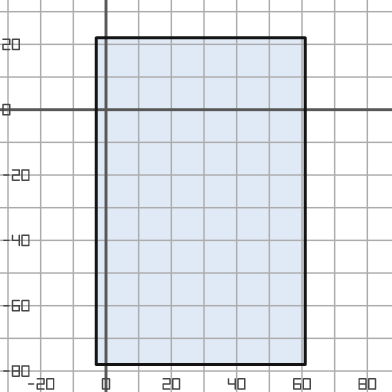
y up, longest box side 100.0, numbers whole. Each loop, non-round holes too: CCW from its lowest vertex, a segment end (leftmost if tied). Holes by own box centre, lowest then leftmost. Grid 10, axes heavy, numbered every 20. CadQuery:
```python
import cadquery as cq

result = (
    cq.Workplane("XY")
    .moveTo(-3.0, -78.0)
    .lineTo(61.0, -78.0)
    .lineTo(61.0, 22.0)
    .lineTo(-3.0, 22.0)
    .close()
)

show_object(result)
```